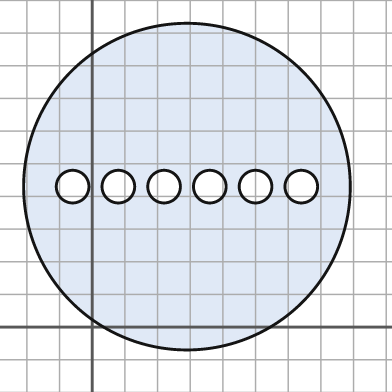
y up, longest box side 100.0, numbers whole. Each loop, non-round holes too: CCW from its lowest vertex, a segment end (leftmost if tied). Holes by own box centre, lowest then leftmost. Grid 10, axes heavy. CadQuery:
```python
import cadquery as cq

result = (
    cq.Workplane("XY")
    .moveTo(29.0, 43.0)
    .circle(50.0)
    .moveTo(-6.0, 43.0)
    .circle(5.0)
    .moveTo(8.0, 43.0)
    .circle(5.0)
    .moveTo(22.0, 43.0)
    .circle(5.0)
    .moveTo(36.0, 43.0)
    .circle(5.0)
    .moveTo(50.0, 43.0)
    .circle(5.0)
    .moveTo(64.0, 43.0)
    .circle(5.0)
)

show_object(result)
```